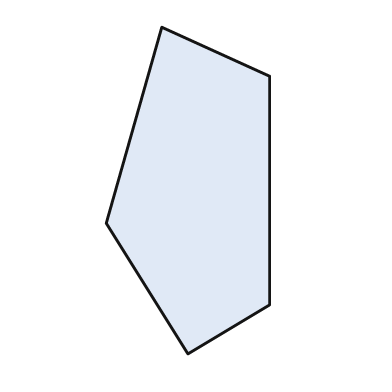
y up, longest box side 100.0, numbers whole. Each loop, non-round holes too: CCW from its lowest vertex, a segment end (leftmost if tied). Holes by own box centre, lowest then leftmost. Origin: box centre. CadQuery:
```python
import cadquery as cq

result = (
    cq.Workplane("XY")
    .moveTo(0.0, -50.0)
    .lineTo(25.0, -35.0)
    .lineTo(25.0, 35.0)
    .lineTo(-8.0, 50.0)
    .lineTo(-25.0, -10.0)
    .close()
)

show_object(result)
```